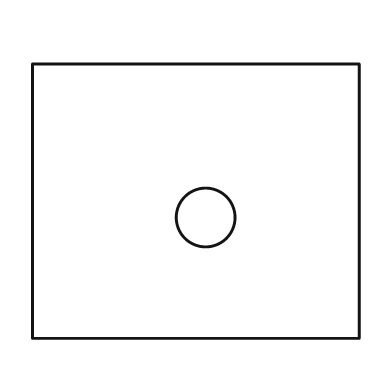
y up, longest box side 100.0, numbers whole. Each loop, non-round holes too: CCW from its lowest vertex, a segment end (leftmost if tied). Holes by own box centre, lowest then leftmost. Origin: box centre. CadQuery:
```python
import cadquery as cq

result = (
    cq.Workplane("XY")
    .moveTo(-50.0, -42.0)
    .lineTo(50.0, -42.0)
    .lineTo(50.0, 42.0)
    .lineTo(-50.0, 42.0)
    .close()
    .moveTo(3.0, -5.0)
    .circle(9.0)
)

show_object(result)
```